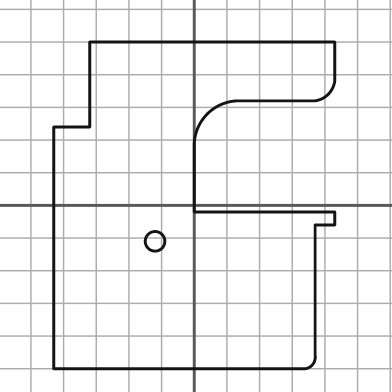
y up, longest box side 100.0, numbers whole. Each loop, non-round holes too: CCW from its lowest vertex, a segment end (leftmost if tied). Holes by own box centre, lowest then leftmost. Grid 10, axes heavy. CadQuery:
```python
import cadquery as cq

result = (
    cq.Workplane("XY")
    .moveTo(-43.0, -50.0)
    .lineTo(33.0, -50.0)
    .threePointArc((36.0, -49.0), (37.0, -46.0))
    .lineTo(37.0, -6.0)
    .lineTo(43.0, -6.0)
    .lineTo(43.0, -2.0)
    .lineTo(0.0, -2.0)
    .lineTo(0.0, 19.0)
    .threePointArc((4.0, 28.0), (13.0, 32.0))
    .lineTo(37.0, 32.0)
    .threePointArc((41.0, 34.0), (43.0, 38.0))
    .lineTo(43.0, 50.0)
    .lineTo(-32.0, 50.0)
    .lineTo(-32.0, 24.0)
    .lineTo(-43.0, 24.0)
    .close()
    .moveTo(-12.0, -11.0)
    .circle(3.0)
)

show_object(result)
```